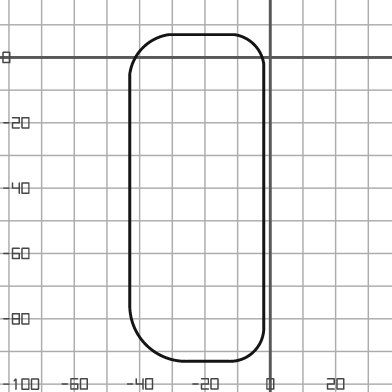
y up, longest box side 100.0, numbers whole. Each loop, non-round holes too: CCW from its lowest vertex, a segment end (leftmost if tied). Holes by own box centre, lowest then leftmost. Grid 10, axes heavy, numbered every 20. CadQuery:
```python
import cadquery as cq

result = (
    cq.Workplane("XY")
    .moveTo(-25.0, -93.0)
    .lineTo(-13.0, -93.0)
    .threePointArc((-5.0, -90.0), (-2.0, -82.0))
    .lineTo(-2.0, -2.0)
    .threePointArc((-5.0, 4.0), (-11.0, 7.0))
    .lineTo(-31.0, 7.0)
    .threePointArc((-39.0, 3.0), (-43.0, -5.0))
    .lineTo(-43.0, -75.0)
    .threePointArc((-38.0, -88.0), (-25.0, -93.0))
    .close()
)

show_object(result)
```